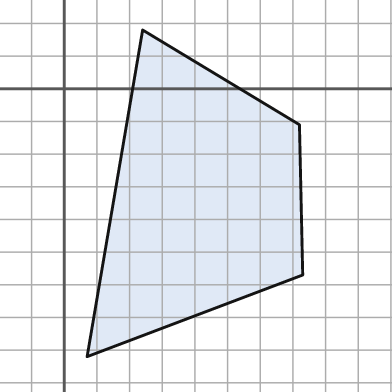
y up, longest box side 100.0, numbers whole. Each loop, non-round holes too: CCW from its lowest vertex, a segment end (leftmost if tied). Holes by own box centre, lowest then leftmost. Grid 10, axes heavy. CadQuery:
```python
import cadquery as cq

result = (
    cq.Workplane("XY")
    .moveTo(7.0, -82.0)
    .lineTo(73.0, -57.0)
    .lineTo(72.0, -11.0)
    .lineTo(24.0, 18.0)
    .close()
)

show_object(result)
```